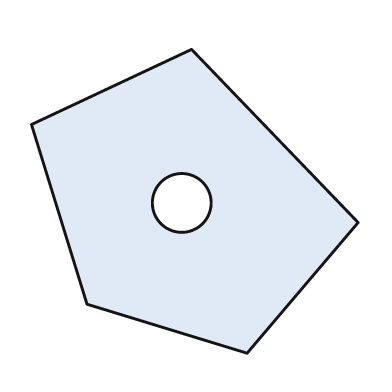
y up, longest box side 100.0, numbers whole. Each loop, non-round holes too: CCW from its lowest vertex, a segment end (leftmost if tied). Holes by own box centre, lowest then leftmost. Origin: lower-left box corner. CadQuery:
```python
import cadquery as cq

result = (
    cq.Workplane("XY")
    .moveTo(66.0, 0.0)
    .lineTo(100.0, 40.0)
    .lineTo(49.0, 93.0)
    .lineTo(0.0, 70.0)
    .lineTo(17.0, 15.0)
    .close()
    .moveTo(46.0, 46.0)
    .circle(9.0)
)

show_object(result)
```